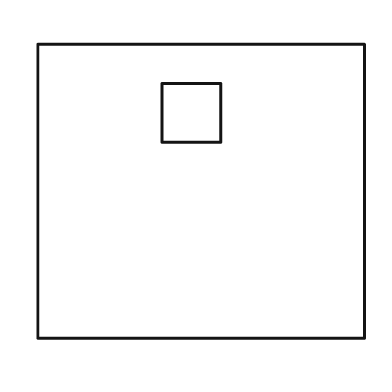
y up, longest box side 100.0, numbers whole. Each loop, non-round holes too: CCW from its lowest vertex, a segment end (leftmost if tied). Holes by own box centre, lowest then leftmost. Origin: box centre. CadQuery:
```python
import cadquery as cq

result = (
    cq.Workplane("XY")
    .moveTo(-50.0, -45.0)
    .lineTo(50.0, -45.0)
    .lineTo(50.0, 45.0)
    .lineTo(-50.0, 45.0)
    .close()
    .moveTo(-12.0, 15.0)
    .lineTo(6.0, 15.0)
    .lineTo(6.0, 33.0)
    .lineTo(-12.0, 33.0)
    .close()
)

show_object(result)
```